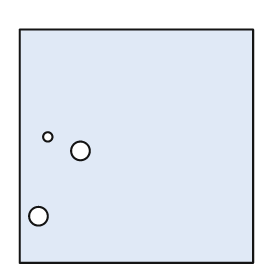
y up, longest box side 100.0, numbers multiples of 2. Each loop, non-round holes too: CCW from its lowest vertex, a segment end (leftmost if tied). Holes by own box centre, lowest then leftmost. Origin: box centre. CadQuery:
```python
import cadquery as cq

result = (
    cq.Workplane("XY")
    .moveTo(-50.0, -50.0)
    .lineTo(50.0, -50.0)
    .lineTo(50.0, 50.0)
    .lineTo(-50.0, 50.0)
    .close()
    .moveTo(-42.0, -30.0)
    .circle(4.0)
    .moveTo(-24.0, -2.0)
    .circle(4.0)
    .moveTo(-38.0, 4.0)
    .circle(2.0)
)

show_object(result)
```